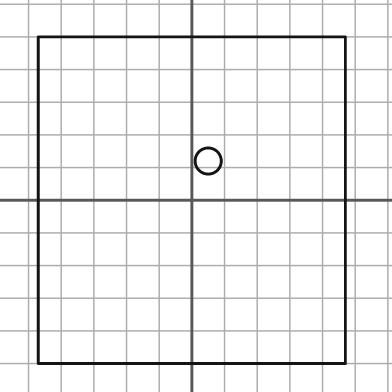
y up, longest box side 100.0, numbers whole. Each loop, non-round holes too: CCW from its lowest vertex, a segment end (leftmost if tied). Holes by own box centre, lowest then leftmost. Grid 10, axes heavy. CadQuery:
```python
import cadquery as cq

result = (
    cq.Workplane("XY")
    .moveTo(-47.0, -50.0)
    .lineTo(47.0, -50.0)
    .lineTo(47.0, 50.0)
    .lineTo(-47.0, 50.0)
    .close()
    .moveTo(5.0, 12.0)
    .circle(4.0)
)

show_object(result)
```